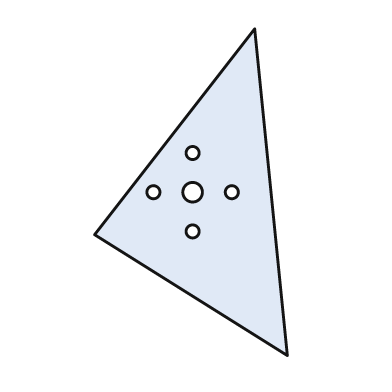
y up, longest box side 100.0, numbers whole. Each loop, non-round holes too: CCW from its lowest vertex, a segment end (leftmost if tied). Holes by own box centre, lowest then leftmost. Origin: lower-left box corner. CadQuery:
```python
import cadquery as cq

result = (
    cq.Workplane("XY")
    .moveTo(59.0, 0.0)
    .lineTo(49.0, 100.0)
    .lineTo(0.0, 37.0)
    .close()
    .moveTo(30.0, 38.0)
    .circle(2.0)
    .moveTo(18.0, 50.0)
    .circle(2.0)
    .moveTo(30.0, 50.0)
    .circle(3.0)
    .moveTo(42.0, 50.0)
    .circle(2.0)
    .moveTo(30.0, 62.0)
    .circle(2.0)
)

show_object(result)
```